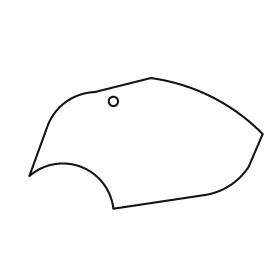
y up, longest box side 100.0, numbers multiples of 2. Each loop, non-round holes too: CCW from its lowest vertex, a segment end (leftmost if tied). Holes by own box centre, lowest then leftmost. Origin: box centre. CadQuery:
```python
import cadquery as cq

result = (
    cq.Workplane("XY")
    .moveTo(-14.0, -28.0)
    .lineTo(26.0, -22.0)
    .threePointArc((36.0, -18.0), (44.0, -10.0))
    .lineTo(50.0, 4.0)
    .threePointArc((28.0, 20.0), (2.0, 28.0))
    .lineTo(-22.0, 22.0)
    .threePointArc((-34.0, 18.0), (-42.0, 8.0))
    .lineTo(-50.0, -14.0)
    .threePointArc((-28.0, -10.0), (-14.0, -28.0))
    .close()
    .moveTo(-14.0, 18.0)
    .circle(2.0)
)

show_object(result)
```